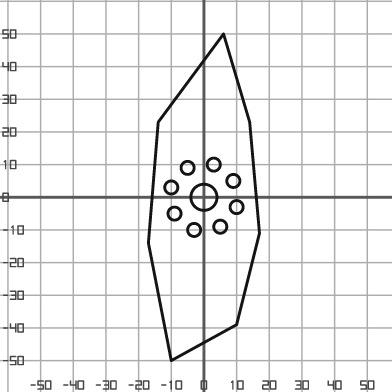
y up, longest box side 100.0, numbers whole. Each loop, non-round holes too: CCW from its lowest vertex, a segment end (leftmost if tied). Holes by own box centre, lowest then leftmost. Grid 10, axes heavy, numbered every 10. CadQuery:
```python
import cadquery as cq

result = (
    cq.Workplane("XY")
    .moveTo(-10.0, -50.0)
    .lineTo(10.0, -39.0)
    .lineTo(17.0, -11.0)
    .lineTo(14.0, 23.0)
    .lineTo(6.0, 50.0)
    .lineTo(-14.0, 23.0)
    .lineTo(-17.0, -14.0)
    .close()
    .moveTo(-3.0, -10.0)
    .circle(2.0)
    .moveTo(5.0, -9.0)
    .circle(2.0)
    .moveTo(-9.0, -5.0)
    .circle(2.0)
    .moveTo(10.0, -3.0)
    .circle(2.0)
    .moveTo(0.0, 0.0)
    .circle(4.0)
    .moveTo(-10.0, 3.0)
    .circle(2.0)
    .moveTo(9.0, 5.0)
    .circle(2.0)
    .moveTo(-5.0, 9.0)
    .circle(2.0)
    .moveTo(3.0, 10.0)
    .circle(2.0)
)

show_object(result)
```